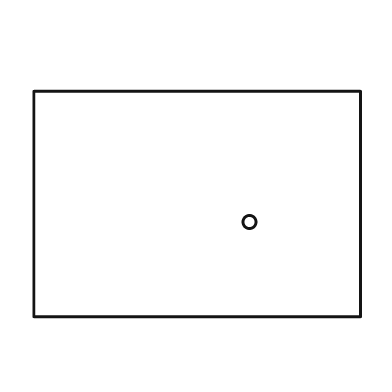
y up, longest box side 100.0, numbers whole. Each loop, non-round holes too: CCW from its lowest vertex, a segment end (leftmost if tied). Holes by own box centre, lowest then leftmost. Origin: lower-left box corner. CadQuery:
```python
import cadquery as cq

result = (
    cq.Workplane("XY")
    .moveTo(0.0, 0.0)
    .lineTo(100.0, 0.0)
    .lineTo(100.0, 69.0)
    .lineTo(0.0, 69.0)
    .close()
    .moveTo(66.0, 29.0)
    .circle(2.0)
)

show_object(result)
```